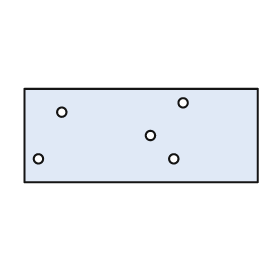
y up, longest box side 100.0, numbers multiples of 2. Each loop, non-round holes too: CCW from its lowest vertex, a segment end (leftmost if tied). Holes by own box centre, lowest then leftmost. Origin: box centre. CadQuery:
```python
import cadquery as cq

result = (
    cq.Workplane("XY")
    .moveTo(-50.0, -20.0)
    .lineTo(50.0, -20.0)
    .lineTo(50.0, 20.0)
    .lineTo(-50.0, 20.0)
    .close()
    .moveTo(-44.0, -10.0)
    .circle(2.0)
    .moveTo(14.0, -10.0)
    .circle(2.0)
    .moveTo(4.0, 0.0)
    .circle(2.0)
    .moveTo(-34.0, 10.0)
    .circle(2.0)
    .moveTo(18.0, 14.0)
    .circle(2.0)
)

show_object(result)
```